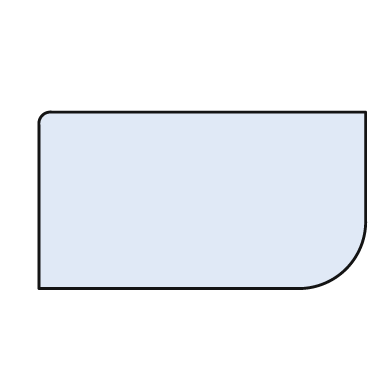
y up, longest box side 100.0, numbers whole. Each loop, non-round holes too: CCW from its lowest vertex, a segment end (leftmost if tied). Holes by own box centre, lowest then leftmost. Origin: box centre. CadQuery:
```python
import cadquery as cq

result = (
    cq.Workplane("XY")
    .moveTo(-50.0, -27.0)
    .lineTo(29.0, -27.0)
    .threePointArc((44.0, -21.0), (50.0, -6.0))
    .lineTo(50.0, 27.0)
    .lineTo(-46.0, 27.0)
    .threePointArc((-49.0, 26.0), (-50.0, 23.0))
    .close()
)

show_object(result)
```